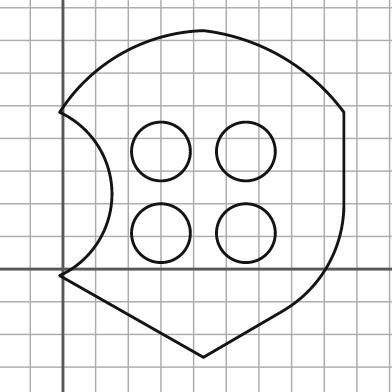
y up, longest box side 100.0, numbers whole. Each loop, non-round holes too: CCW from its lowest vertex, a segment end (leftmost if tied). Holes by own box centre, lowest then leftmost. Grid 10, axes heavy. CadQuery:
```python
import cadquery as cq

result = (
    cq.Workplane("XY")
    .moveTo(43.0, -27.0)
    .lineTo(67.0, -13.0)
    .threePointArc((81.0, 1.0), (86.0, 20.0))
    .lineTo(86.0, 48.0)
    .threePointArc((67.0, 65.0), (43.0, 73.0))
    .threePointArc((18.0, 66.0), (-1.0, 48.0))
    .threePointArc((15.0, 23.0), (-1.0, -2.0))
    .close()
    .moveTo(30.0, 11.0)
    .circle(9.0)
    .moveTo(56.0, 11.0)
    .circle(9.0)
    .moveTo(30.0, 36.0)
    .circle(9.0)
    .moveTo(56.0, 36.0)
    .circle(9.0)
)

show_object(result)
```